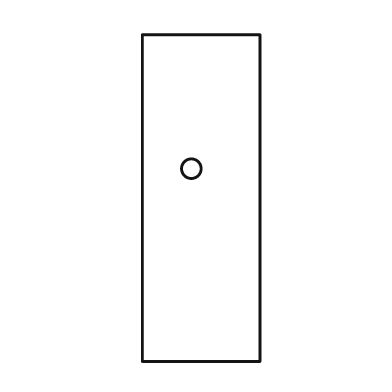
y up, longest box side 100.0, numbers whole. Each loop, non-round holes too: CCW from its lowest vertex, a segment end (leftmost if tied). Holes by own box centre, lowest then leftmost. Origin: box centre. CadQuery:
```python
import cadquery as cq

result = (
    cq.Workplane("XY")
    .moveTo(-18.0, -50.0)
    .lineTo(18.0, -50.0)
    .lineTo(18.0, 50.0)
    .lineTo(-18.0, 50.0)
    .close()
    .moveTo(-3.0, 9.0)
    .circle(3.0)
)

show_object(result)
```